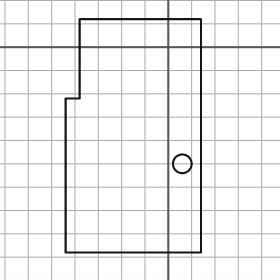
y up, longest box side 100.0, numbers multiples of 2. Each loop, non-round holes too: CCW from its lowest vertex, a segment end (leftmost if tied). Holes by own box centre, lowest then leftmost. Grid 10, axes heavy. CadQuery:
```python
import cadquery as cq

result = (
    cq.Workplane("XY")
    .moveTo(-44.0, -88.0)
    .lineTo(14.0, -88.0)
    .lineTo(14.0, 12.0)
    .lineTo(-38.0, 12.0)
    .lineTo(-38.0, -22.0)
    .lineTo(-44.0, -22.0)
    .close()
    .moveTo(6.0, -50.0)
    .circle(4.0)
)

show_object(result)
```